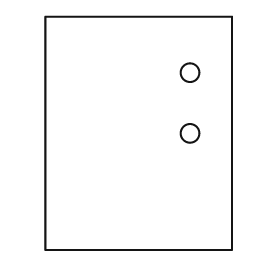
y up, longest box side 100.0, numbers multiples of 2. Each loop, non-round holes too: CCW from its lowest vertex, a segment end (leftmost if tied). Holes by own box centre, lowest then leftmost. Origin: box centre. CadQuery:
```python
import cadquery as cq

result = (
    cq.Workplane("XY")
    .moveTo(-40.0, -50.0)
    .lineTo(40.0, -50.0)
    .lineTo(40.0, 50.0)
    .lineTo(-40.0, 50.0)
    .close()
    .moveTo(22.0, 0.0)
    .circle(4.0)
    .moveTo(22.0, 26.0)
    .circle(4.0)
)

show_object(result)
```